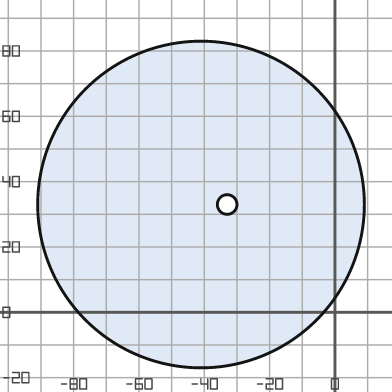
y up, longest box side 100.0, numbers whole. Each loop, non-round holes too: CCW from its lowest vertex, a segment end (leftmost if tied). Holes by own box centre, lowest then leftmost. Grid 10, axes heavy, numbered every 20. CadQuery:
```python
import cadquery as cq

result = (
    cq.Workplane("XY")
    .moveTo(-41.0, 33.0)
    .circle(50.0)
    .moveTo(-33.0, 33.0)
    .circle(3.0)
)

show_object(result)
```